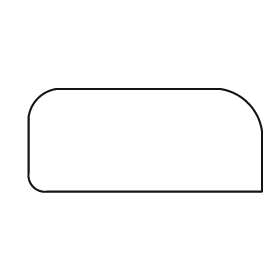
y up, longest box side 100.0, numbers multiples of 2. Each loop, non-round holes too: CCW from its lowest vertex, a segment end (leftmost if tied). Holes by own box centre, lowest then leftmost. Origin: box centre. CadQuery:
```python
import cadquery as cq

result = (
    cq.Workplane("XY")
    .moveTo(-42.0, -22.0)
    .lineTo(50.0, -22.0)
    .lineTo(50.0, 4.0)
    .threePointArc((44.0, 16.0), (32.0, 22.0))
    .lineTo(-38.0, 22.0)
    .threePointArc((-46.0, 18.0), (-50.0, 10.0))
    .lineTo(-50.0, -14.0)
    .threePointArc((-48.0, -20.0), (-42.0, -22.0))
    .close()
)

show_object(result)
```